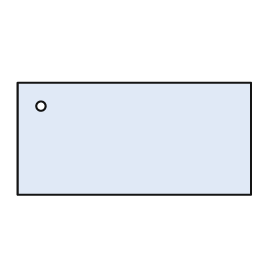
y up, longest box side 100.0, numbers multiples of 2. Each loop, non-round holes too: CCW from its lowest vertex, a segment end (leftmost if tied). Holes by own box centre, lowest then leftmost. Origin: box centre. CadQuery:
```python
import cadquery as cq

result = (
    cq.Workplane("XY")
    .moveTo(-50.0, -24.0)
    .lineTo(50.0, -24.0)
    .lineTo(50.0, 24.0)
    .lineTo(-50.0, 24.0)
    .close()
    .moveTo(-40.0, 14.0)
    .circle(2.0)
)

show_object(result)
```